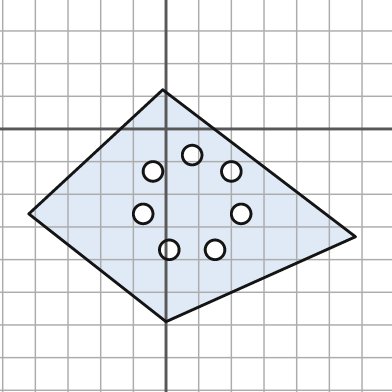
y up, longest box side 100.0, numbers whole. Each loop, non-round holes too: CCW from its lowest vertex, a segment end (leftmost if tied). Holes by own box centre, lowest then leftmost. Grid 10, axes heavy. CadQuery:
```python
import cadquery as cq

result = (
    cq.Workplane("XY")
    .moveTo(0.0, -59.0)
    .lineTo(58.0, -33.0)
    .lineTo(-1.0, 12.0)
    .lineTo(-42.0, -26.0)
    .close()
    .moveTo(1.0, -37.0)
    .circle(3.0)
    .moveTo(15.0, -37.0)
    .circle(3.0)
    .moveTo(-7.0, -26.0)
    .circle(3.0)
    .moveTo(23.0, -26.0)
    .circle(3.0)
    .moveTo(-4.0, -13.0)
    .circle(3.0)
    .moveTo(20.0, -13.0)
    .circle(3.0)
    .moveTo(8.0, -8.0)
    .circle(3.0)
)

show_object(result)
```